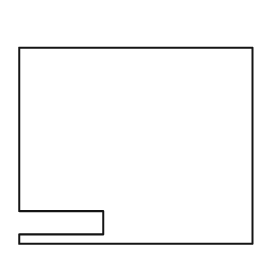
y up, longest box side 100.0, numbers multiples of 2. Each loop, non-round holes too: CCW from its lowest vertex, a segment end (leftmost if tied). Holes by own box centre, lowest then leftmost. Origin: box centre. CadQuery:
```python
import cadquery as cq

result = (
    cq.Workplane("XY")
    .moveTo(-50.0, -42.0)
    .lineTo(50.0, -42.0)
    .lineTo(50.0, 42.0)
    .lineTo(-50.0, 42.0)
    .lineTo(-50.0, -28.0)
    .lineTo(-14.0, -28.0)
    .lineTo(-14.0, -38.0)
    .lineTo(-50.0, -38.0)
    .close()
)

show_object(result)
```